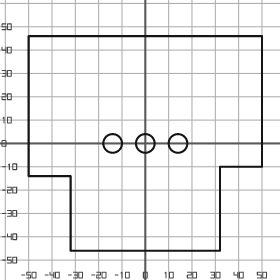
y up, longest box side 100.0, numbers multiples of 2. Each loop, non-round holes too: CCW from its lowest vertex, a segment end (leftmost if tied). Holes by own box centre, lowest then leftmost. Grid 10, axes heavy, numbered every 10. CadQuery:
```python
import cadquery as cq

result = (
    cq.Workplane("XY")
    .moveTo(-32.0, -46.0)
    .lineTo(32.0, -46.0)
    .lineTo(32.0, -10.0)
    .lineTo(50.0, -10.0)
    .lineTo(50.0, 46.0)
    .lineTo(-50.0, 46.0)
    .lineTo(-50.0, -14.0)
    .lineTo(-32.0, -14.0)
    .close()
    .moveTo(-14.0, 0.0)
    .circle(4.0)
    .moveTo(0.0, 0.0)
    .circle(4.0)
    .moveTo(14.0, 0.0)
    .circle(4.0)
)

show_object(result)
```